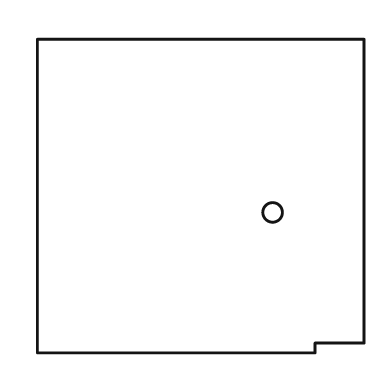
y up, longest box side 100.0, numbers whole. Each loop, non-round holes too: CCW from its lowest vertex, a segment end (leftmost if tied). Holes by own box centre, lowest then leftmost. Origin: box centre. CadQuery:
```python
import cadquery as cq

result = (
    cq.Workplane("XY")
    .moveTo(-50.0, -48.0)
    .lineTo(35.0, -48.0)
    .lineTo(35.0, -45.0)
    .lineTo(50.0, -45.0)
    .lineTo(50.0, 48.0)
    .lineTo(-50.0, 48.0)
    .close()
    .moveTo(22.0, -5.0)
    .circle(3.0)
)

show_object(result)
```